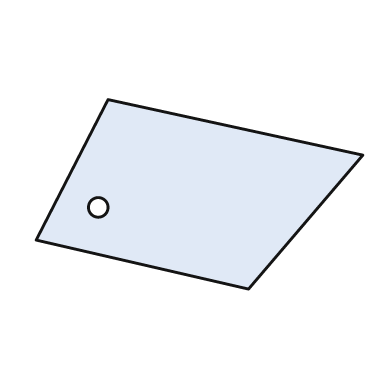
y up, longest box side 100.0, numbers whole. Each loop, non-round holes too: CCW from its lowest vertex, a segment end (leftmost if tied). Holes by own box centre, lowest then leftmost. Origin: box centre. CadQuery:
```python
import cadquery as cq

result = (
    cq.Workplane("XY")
    .moveTo(15.0, -29.0)
    .lineTo(50.0, 12.0)
    .lineTo(-28.0, 29.0)
    .lineTo(-50.0, -14.0)
    .close()
    .moveTo(-31.0, -4.0)
    .circle(3.0)
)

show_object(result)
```